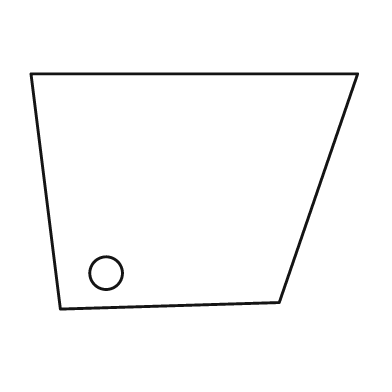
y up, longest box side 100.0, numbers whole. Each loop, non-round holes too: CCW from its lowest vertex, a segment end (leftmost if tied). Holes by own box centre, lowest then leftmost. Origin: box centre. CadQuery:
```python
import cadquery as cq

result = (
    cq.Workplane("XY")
    .moveTo(-41.0, -36.0)
    .lineTo(26.0, -34.0)
    .lineTo(50.0, 36.0)
    .lineTo(-50.0, 36.0)
    .close()
    .moveTo(-27.0, -25.0)
    .circle(5.0)
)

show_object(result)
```